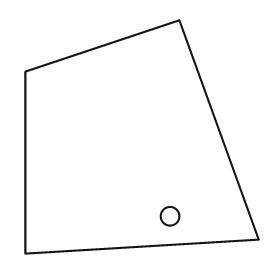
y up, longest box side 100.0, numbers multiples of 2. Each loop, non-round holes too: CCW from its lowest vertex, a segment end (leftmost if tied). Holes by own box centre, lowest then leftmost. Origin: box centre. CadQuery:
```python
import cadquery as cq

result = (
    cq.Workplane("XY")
    .moveTo(-50.0, -50.0)
    .lineTo(50.0, -44.0)
    .lineTo(16.0, 50.0)
    .lineTo(-50.0, 28.0)
    .close()
    .moveTo(12.0, -34.0)
    .circle(4.0)
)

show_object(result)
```